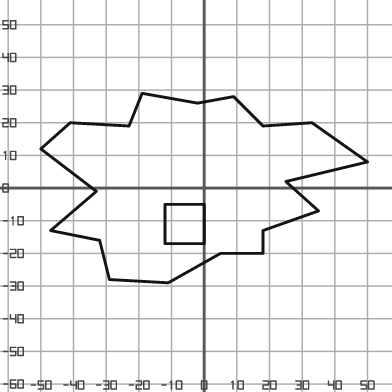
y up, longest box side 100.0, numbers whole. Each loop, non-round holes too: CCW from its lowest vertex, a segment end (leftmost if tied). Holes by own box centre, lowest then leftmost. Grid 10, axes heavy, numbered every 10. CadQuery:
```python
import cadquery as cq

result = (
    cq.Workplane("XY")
    .moveTo(-11.0, -29.0)
    .lineTo(5.0, -20.0)
    .lineTo(18.0, -20.0)
    .lineTo(18.0, -13.0)
    .lineTo(35.0, -7.0)
    .lineTo(25.0, 2.0)
    .lineTo(50.0, 8.0)
    .lineTo(33.0, 20.0)
    .lineTo(18.0, 19.0)
    .lineTo(9.0, 28.0)
    .lineTo(-2.0, 26.0)
    .lineTo(-19.0, 29.0)
    .lineTo(-23.0, 19.0)
    .lineTo(-41.0, 20.0)
    .lineTo(-50.0, 12.0)
    .lineTo(-33.0, -1.0)
    .lineTo(-47.0, -13.0)
    .lineTo(-32.0, -16.0)
    .lineTo(-29.0, -28.0)
    .close()
    .moveTo(-12.0, -17.0)
    .lineTo(0.0, -17.0)
    .lineTo(0.0, -5.0)
    .lineTo(-12.0, -5.0)
    .close()
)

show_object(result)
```